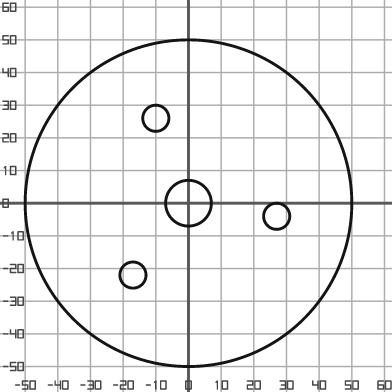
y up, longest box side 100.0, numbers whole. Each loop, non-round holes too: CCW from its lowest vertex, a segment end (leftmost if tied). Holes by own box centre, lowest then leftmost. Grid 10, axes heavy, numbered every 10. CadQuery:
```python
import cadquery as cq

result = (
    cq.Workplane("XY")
    .moveTo(0.0, 0.0)
    .circle(50.0)
    .moveTo(-17.0, -22.0)
    .circle(4.0)
    .moveTo(27.0, -4.0)
    .circle(4.0)
    .moveTo(0.0, 0.0)
    .circle(7.0)
    .moveTo(-10.0, 26.0)
    .circle(4.0)
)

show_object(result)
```